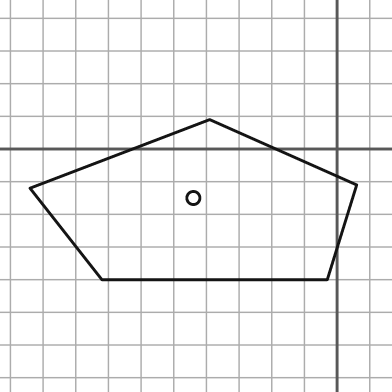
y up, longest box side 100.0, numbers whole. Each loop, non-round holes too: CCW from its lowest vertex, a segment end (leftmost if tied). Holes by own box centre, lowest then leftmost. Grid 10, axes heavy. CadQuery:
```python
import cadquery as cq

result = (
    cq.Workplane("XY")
    .moveTo(-72.0, -40.0)
    .lineTo(-3.0, -40.0)
    .lineTo(6.0, -11.0)
    .lineTo(-39.0, 9.0)
    .lineTo(-94.0, -12.0)
    .close()
    .moveTo(-44.0, -15.0)
    .circle(2.0)
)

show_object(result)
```